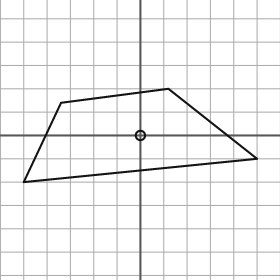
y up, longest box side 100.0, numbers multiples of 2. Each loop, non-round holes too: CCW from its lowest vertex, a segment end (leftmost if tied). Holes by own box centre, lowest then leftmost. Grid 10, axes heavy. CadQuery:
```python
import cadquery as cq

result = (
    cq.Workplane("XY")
    .moveTo(-50.0, -20.0)
    .lineTo(50.0, -10.0)
    .lineTo(12.0, 20.0)
    .lineTo(-34.0, 14.0)
    .close()
    .moveTo(0.0, 0.0)
    .circle(2.0)
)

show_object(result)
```